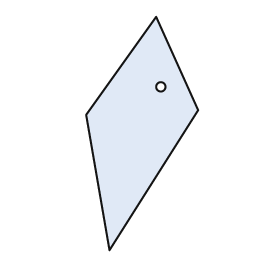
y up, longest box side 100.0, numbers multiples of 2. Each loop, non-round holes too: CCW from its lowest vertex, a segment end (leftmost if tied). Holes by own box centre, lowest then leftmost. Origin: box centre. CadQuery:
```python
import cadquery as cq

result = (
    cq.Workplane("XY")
    .moveTo(-14.0, -50.0)
    .lineTo(24.0, 10.0)
    .lineTo(6.0, 50.0)
    .lineTo(-24.0, 8.0)
    .close()
    .moveTo(8.0, 20.0)
    .circle(2.0)
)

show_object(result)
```